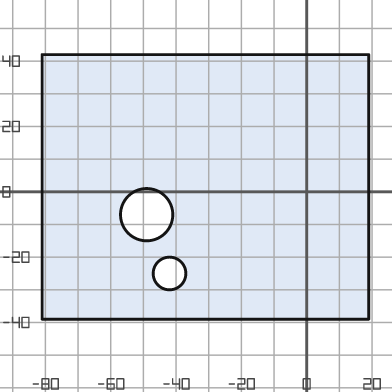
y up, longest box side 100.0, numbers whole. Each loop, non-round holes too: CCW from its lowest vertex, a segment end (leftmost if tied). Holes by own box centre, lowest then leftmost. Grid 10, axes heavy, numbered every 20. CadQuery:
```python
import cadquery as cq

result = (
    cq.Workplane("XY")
    .moveTo(-81.0, -39.0)
    .lineTo(19.0, -39.0)
    .lineTo(19.0, 42.0)
    .lineTo(-81.0, 42.0)
    .close()
    .moveTo(-42.0, -25.0)
    .circle(5.0)
    .moveTo(-49.0, -7.0)
    .circle(8.0)
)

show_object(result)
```